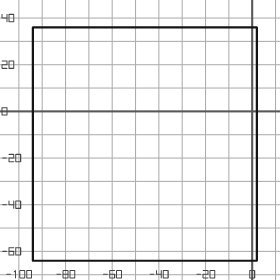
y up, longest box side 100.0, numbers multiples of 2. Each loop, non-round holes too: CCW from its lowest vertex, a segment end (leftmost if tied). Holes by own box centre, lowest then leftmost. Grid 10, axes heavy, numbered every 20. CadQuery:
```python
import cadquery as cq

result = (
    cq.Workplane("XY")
    .moveTo(-94.0, -64.0)
    .lineTo(2.0, -64.0)
    .lineTo(2.0, 36.0)
    .lineTo(-94.0, 36.0)
    .close()
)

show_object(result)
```